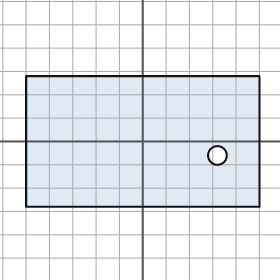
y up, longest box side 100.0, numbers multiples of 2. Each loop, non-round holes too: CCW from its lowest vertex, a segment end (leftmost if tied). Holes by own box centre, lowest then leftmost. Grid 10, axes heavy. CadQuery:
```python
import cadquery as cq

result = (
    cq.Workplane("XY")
    .moveTo(-50.0, -28.0)
    .lineTo(50.0, -28.0)
    .lineTo(50.0, 28.0)
    .lineTo(-50.0, 28.0)
    .close()
    .moveTo(32.0, -6.0)
    .circle(4.0)
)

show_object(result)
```